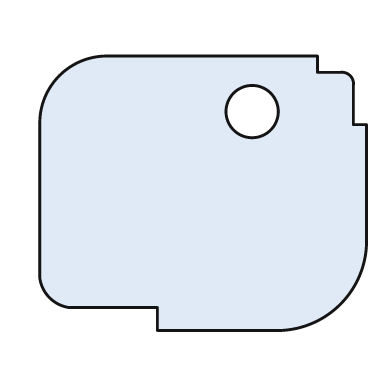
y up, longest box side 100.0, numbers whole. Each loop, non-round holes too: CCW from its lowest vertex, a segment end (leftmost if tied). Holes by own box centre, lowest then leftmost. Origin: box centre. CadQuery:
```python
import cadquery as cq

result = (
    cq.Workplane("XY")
    .moveTo(-14.0, -42.0)
    .lineTo(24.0, -42.0)
    .threePointArc((42.0, -34.0), (50.0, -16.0))
    .lineTo(50.0, 21.0)
    .lineTo(46.0, 21.0)
    .lineTo(46.0, 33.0)
    .threePointArc((45.0, 36.0), (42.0, 37.0))
    .lineTo(35.0, 37.0)
    .lineTo(35.0, 42.0)
    .lineTo(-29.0, 42.0)
    .threePointArc((-44.0, 36.0), (-50.0, 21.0))
    .lineTo(-50.0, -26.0)
    .threePointArc((-47.0, -32.0), (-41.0, -35.0))
    .lineTo(-14.0, -35.0)
    .close()
    .moveTo(15.0, 25.0)
    .circle(8.0)
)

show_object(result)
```